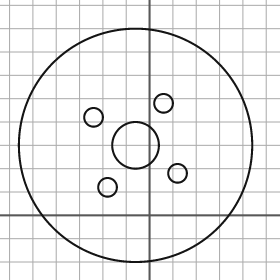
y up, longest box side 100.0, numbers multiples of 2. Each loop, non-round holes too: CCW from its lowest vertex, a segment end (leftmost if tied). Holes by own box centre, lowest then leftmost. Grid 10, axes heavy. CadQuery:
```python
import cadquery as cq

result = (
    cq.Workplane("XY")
    .moveTo(-6.0, 30.0)
    .circle(50.0)
    .moveTo(-18.0, 12.0)
    .circle(4.0)
    .moveTo(12.0, 18.0)
    .circle(4.0)
    .moveTo(-6.0, 30.0)
    .circle(10.0)
    .moveTo(-24.0, 42.0)
    .circle(4.0)
    .moveTo(6.0, 48.0)
    .circle(4.0)
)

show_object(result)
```